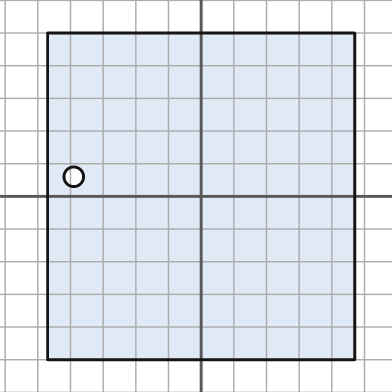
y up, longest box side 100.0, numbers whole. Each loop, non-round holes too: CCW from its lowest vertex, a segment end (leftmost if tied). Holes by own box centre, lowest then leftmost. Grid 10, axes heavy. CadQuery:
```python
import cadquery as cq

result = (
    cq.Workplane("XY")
    .moveTo(-47.0, -50.0)
    .lineTo(47.0, -50.0)
    .lineTo(47.0, 50.0)
    .lineTo(-47.0, 50.0)
    .close()
    .moveTo(-39.0, 6.0)
    .circle(3.0)
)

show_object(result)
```